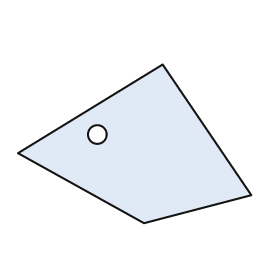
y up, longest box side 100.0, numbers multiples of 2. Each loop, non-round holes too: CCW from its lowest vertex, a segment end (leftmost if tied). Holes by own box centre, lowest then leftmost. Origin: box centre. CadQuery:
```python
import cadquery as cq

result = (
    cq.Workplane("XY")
    .moveTo(4.0, -34.0)
    .lineTo(50.0, -22.0)
    .lineTo(12.0, 34.0)
    .lineTo(-50.0, -4.0)
    .close()
    .moveTo(-16.0, 4.0)
    .circle(4.0)
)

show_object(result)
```